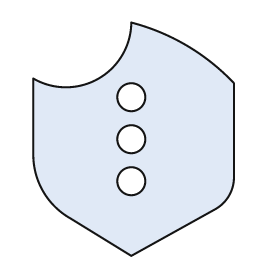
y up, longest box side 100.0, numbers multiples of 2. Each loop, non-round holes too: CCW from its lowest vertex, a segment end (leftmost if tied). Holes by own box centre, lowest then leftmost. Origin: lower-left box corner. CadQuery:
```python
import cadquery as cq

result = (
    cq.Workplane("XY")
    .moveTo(42.0, 0.0)
    .lineTo(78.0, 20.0)
    .threePointArc((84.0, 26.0), (86.0, 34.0))
    .lineTo(86.0, 74.0)
    .threePointArc((66.0, 90.0), (42.0, 100.0))
    .threePointArc((28.0, 76.0), (0.0, 76.0))
    .lineTo(0.0, 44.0)
    .threePointArc((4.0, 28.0), (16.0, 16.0))
    .close()
    .moveTo(42.0, 32.0)
    .circle(6.0)
    .moveTo(42.0, 50.0)
    .circle(6.0)
    .moveTo(42.0, 68.0)
    .circle(6.0)
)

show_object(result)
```